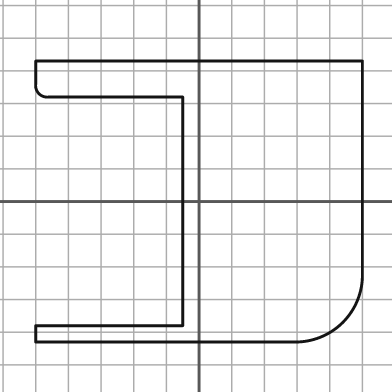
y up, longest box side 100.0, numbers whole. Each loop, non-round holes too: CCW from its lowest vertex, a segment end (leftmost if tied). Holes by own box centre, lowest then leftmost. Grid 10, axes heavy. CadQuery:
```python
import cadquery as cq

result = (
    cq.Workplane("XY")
    .moveTo(-50.0, -43.0)
    .lineTo(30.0, -43.0)
    .threePointArc((44.0, -37.0), (50.0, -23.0))
    .lineTo(50.0, 43.0)
    .lineTo(-50.0, 43.0)
    .lineTo(-50.0, 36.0)
    .threePointArc((-49.0, 33.0), (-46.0, 32.0))
    .lineTo(-5.0, 32.0)
    .lineTo(-5.0, -38.0)
    .lineTo(-50.0, -38.0)
    .close()
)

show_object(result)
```